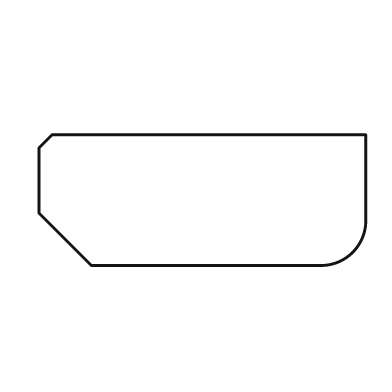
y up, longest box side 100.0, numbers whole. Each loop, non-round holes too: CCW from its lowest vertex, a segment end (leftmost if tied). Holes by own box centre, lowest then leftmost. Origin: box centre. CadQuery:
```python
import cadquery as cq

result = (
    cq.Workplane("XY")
    .moveTo(-34.0, -20.0)
    .lineTo(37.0, -20.0)
    .threePointArc((46.0, -16.0), (50.0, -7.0))
    .lineTo(50.0, 20.0)
    .lineTo(-46.0, 20.0)
    .lineTo(-50.0, 16.0)
    .lineTo(-50.0, -4.0)
    .close()
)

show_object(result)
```